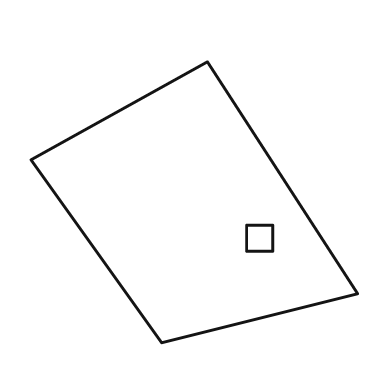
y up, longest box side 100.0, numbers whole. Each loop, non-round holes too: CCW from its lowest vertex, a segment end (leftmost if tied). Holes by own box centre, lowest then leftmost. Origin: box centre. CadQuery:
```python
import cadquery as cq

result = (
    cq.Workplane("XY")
    .moveTo(-10.0, -43.0)
    .lineTo(50.0, -28.0)
    .lineTo(4.0, 43.0)
    .lineTo(-50.0, 13.0)
    .close()
    .moveTo(16.0, -15.0)
    .lineTo(24.0, -15.0)
    .lineTo(24.0, -7.0)
    .lineTo(16.0, -7.0)
    .close()
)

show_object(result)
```